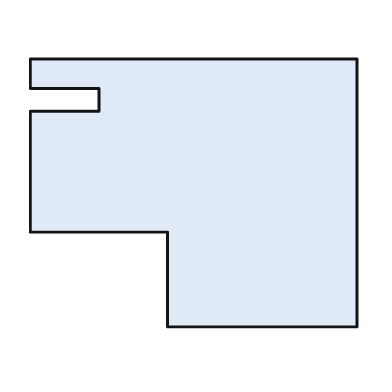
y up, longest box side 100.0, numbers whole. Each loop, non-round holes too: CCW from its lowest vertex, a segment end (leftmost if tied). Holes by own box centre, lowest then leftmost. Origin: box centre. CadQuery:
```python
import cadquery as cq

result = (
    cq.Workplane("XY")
    .moveTo(-8.0, -41.0)
    .lineTo(50.0, -41.0)
    .lineTo(50.0, 41.0)
    .lineTo(-50.0, 41.0)
    .lineTo(-50.0, 32.0)
    .lineTo(-29.0, 32.0)
    .lineTo(-29.0, 25.0)
    .lineTo(-50.0, 25.0)
    .lineTo(-50.0, -12.0)
    .lineTo(-8.0, -12.0)
    .close()
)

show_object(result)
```